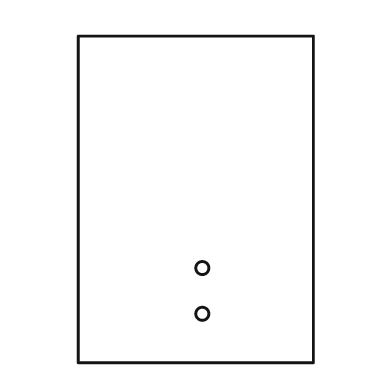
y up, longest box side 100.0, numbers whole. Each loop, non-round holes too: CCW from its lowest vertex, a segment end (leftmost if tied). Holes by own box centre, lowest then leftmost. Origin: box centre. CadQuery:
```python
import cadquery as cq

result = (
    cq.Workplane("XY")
    .moveTo(-36.0, -50.0)
    .lineTo(36.0, -50.0)
    .lineTo(36.0, 50.0)
    .lineTo(-36.0, 50.0)
    .close()
    .moveTo(2.0, -35.0)
    .circle(2.0)
    .moveTo(2.0, -21.0)
    .circle(2.0)
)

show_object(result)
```